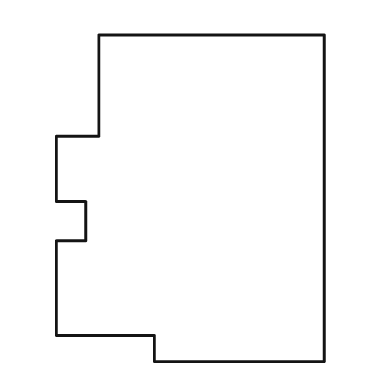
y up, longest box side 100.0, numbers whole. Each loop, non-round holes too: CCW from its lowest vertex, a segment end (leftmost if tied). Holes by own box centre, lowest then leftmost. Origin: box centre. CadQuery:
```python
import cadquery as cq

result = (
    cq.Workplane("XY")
    .moveTo(-11.0, -50.0)
    .lineTo(41.0, -50.0)
    .lineTo(41.0, 50.0)
    .lineTo(-28.0, 50.0)
    .lineTo(-28.0, 19.0)
    .lineTo(-41.0, 19.0)
    .lineTo(-41.0, -1.0)
    .lineTo(-32.0, -1.0)
    .lineTo(-32.0, -13.0)
    .lineTo(-41.0, -13.0)
    .lineTo(-41.0, -42.0)
    .lineTo(-11.0, -42.0)
    .close()
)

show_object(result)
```